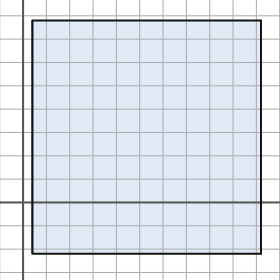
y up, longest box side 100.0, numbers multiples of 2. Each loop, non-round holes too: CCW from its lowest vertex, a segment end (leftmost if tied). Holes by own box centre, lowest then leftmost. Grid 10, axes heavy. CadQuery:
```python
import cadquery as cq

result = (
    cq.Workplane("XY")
    .moveTo(4.0, -22.0)
    .lineTo(102.0, -22.0)
    .lineTo(102.0, 78.0)
    .lineTo(4.0, 78.0)
    .close()
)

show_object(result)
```